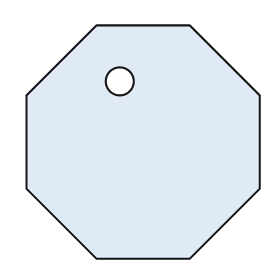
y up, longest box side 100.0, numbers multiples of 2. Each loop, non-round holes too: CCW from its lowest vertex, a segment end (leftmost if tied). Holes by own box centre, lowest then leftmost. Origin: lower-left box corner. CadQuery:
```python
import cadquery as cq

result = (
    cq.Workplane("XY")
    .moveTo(30.0, 0.0)
    .lineTo(70.0, 0.0)
    .lineTo(100.0, 30.0)
    .lineTo(100.0, 70.0)
    .lineTo(70.0, 100.0)
    .lineTo(30.0, 100.0)
    .lineTo(0.0, 70.0)
    .lineTo(0.0, 30.0)
    .close()
    .moveTo(40.0, 76.0)
    .circle(6.0)
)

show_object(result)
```